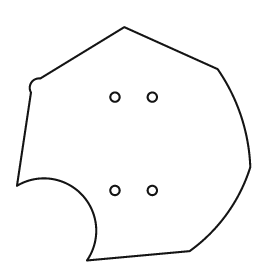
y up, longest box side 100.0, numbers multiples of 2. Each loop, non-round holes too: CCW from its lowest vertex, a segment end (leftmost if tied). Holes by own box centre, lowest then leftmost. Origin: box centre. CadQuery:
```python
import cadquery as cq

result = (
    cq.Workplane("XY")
    .moveTo(-20.0, -50.0)
    .lineTo(24.0, -46.0)
    .threePointArc((40.0, -30.0), (50.0, -10.0))
    .threePointArc((46.0, 12.0), (36.0, 32.0))
    .lineTo(-4.0, 50.0)
    .lineTo(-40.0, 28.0)
    .threePointArc((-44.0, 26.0), (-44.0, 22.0))
    .lineTo(-50.0, -18.0)
    .threePointArc((-22.0, -22.0), (-20.0, -50.0))
    .close()
    .moveTo(-8.0, -20.0)
    .circle(2.0)
    .moveTo(8.0, -20.0)
    .circle(2.0)
    .moveTo(-8.0, 20.0)
    .circle(2.0)
    .moveTo(8.0, 20.0)
    .circle(2.0)
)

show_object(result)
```